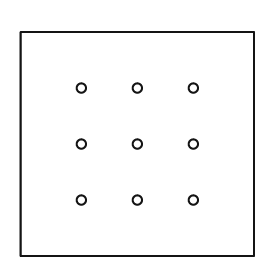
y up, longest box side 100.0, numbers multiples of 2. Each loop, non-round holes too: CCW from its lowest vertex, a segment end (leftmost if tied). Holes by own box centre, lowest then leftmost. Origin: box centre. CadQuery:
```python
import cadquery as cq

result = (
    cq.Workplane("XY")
    .moveTo(-50.0, -48.0)
    .lineTo(50.0, -48.0)
    .lineTo(50.0, 48.0)
    .lineTo(-50.0, 48.0)
    .close()
    .moveTo(-24.0, -24.0)
    .circle(2.0)
    .moveTo(0.0, -24.0)
    .circle(2.0)
    .moveTo(24.0, -24.0)
    .circle(2.0)
    .moveTo(-24.0, 0.0)
    .circle(2.0)
    .moveTo(0.0, 0.0)
    .circle(2.0)
    .moveTo(24.0, 0.0)
    .circle(2.0)
    .moveTo(-24.0, 24.0)
    .circle(2.0)
    .moveTo(0.0, 24.0)
    .circle(2.0)
    .moveTo(24.0, 24.0)
    .circle(2.0)
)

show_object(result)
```